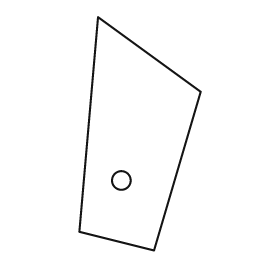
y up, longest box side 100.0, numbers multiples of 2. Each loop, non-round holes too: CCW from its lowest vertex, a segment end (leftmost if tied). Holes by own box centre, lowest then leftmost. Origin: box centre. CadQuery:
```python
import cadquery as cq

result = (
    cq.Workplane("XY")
    .moveTo(6.0, -50.0)
    .lineTo(26.0, 18.0)
    .lineTo(-18.0, 50.0)
    .lineTo(-26.0, -42.0)
    .close()
    .moveTo(-8.0, -20.0)
    .circle(4.0)
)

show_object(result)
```